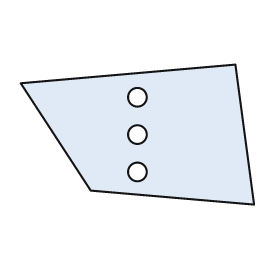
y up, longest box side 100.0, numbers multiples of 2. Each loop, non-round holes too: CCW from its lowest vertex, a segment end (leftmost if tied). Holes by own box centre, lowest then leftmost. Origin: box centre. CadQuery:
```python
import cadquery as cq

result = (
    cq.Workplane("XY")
    .moveTo(50.0, -30.0)
    .lineTo(42.0, 30.0)
    .lineTo(-50.0, 22.0)
    .lineTo(-20.0, -24.0)
    .close()
    .moveTo(0.0, -16.0)
    .circle(4.0)
    .moveTo(0.0, 0.0)
    .circle(4.0)
    .moveTo(0.0, 16.0)
    .circle(4.0)
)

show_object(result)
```